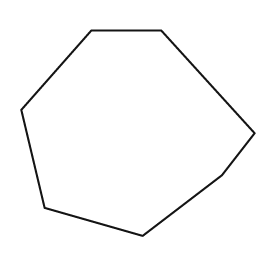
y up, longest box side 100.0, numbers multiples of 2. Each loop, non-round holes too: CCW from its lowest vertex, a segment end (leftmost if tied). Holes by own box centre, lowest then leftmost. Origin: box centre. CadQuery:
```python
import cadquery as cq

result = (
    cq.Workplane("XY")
    .moveTo(2.0, -44.0)
    .lineTo(36.0, -18.0)
    .lineTo(50.0, 0.0)
    .lineTo(10.0, 44.0)
    .lineTo(-20.0, 44.0)
    .lineTo(-50.0, 10.0)
    .lineTo(-40.0, -32.0)
    .close()
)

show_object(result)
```